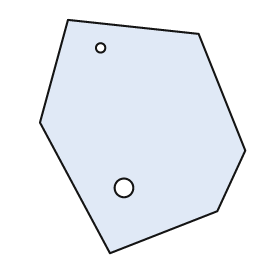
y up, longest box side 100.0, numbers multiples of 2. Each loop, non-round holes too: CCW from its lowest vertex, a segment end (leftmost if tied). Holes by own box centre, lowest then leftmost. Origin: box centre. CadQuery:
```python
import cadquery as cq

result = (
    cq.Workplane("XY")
    .moveTo(-14.0, -50.0)
    .lineTo(32.0, -32.0)
    .lineTo(44.0, -6.0)
    .lineTo(24.0, 44.0)
    .lineTo(-32.0, 50.0)
    .lineTo(-44.0, 6.0)
    .close()
    .moveTo(-8.0, -22.0)
    .circle(4.0)
    .moveTo(-18.0, 38.0)
    .circle(2.0)
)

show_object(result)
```